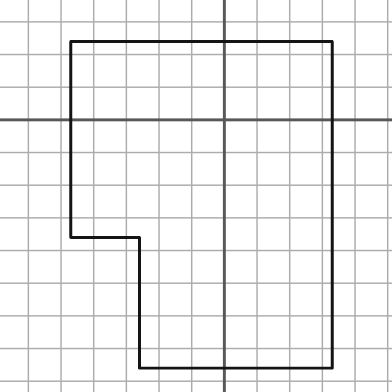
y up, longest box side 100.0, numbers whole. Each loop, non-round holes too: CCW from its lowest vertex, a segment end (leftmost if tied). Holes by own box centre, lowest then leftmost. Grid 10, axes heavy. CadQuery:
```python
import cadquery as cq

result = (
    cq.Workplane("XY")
    .moveTo(-26.0, -76.0)
    .lineTo(33.0, -76.0)
    .lineTo(33.0, 24.0)
    .lineTo(-47.0, 24.0)
    .lineTo(-47.0, -36.0)
    .lineTo(-26.0, -36.0)
    .close()
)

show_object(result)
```